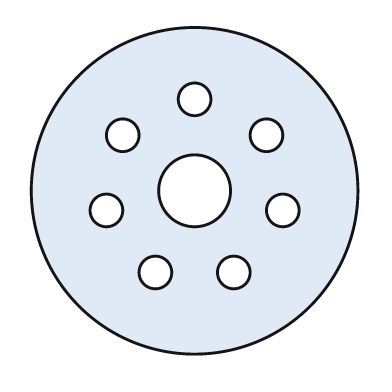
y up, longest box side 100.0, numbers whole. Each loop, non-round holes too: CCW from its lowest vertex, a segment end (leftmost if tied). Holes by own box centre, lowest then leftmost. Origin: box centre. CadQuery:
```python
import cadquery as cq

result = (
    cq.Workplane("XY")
    .moveTo(0.0, 0.0)
    .circle(50.0)
    .moveTo(-12.0, -25.0)
    .circle(5.0)
    .moveTo(12.0, -25.0)
    .circle(5.0)
    .moveTo(-27.0, -6.0)
    .circle(5.0)
    .moveTo(27.0, -6.0)
    .circle(5.0)
    .moveTo(0.0, 0.0)
    .circle(11.0)
    .moveTo(-22.0, 17.0)
    .circle(5.0)
    .moveTo(22.0, 17.0)
    .circle(5.0)
    .moveTo(0.0, 28.0)
    .circle(5.0)
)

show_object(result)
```